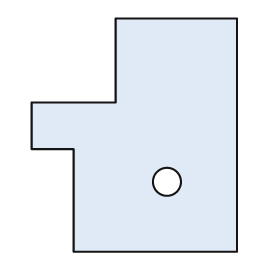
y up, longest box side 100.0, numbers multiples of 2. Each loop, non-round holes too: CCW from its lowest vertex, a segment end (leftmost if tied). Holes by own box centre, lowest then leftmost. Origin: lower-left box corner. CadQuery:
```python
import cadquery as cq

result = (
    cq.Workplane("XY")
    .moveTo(18.0, 0.0)
    .lineTo(88.0, 0.0)
    .lineTo(88.0, 100.0)
    .lineTo(36.0, 100.0)
    .lineTo(36.0, 64.0)
    .lineTo(0.0, 64.0)
    .lineTo(0.0, 44.0)
    .lineTo(18.0, 44.0)
    .close()
    .moveTo(58.0, 30.0)
    .circle(6.0)
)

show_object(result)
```